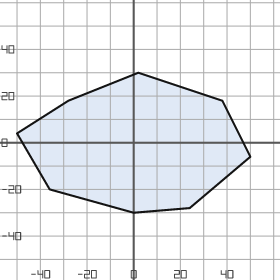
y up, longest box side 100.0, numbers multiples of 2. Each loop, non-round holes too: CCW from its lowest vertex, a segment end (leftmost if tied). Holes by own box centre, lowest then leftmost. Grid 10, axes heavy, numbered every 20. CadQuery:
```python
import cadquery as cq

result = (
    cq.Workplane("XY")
    .moveTo(0.0, -30.0)
    .lineTo(24.0, -28.0)
    .lineTo(50.0, -6.0)
    .lineTo(38.0, 18.0)
    .lineTo(2.0, 30.0)
    .lineTo(-28.0, 18.0)
    .lineTo(-50.0, 4.0)
    .lineTo(-36.0, -20.0)
    .close()
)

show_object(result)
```